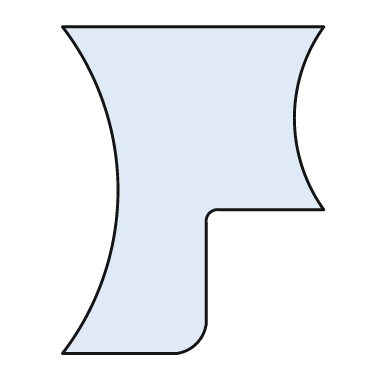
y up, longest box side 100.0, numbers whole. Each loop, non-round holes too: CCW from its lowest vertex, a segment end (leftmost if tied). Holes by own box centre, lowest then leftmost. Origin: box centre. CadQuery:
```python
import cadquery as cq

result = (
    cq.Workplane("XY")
    .moveTo(-40.0, -50.0)
    .lineTo(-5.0, -50.0)
    .threePointArc((1.0, -47.0), (4.0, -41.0))
    .lineTo(4.0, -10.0)
    .threePointArc((5.0, -7.0), (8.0, -6.0))
    .lineTo(40.0, -6.0)
    .threePointArc((31.0, 22.0), (40.0, 50.0))
    .lineTo(-40.0, 50.0)
    .threePointArc((-23.0, 0.0), (-40.0, -50.0))
    .close()
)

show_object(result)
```